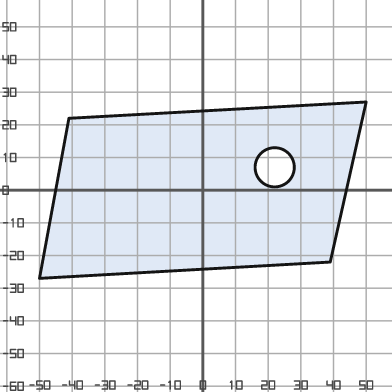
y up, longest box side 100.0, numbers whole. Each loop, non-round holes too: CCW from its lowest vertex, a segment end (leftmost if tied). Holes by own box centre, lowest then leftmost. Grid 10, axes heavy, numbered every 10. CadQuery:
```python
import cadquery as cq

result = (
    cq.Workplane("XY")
    .moveTo(-50.0, -27.0)
    .lineTo(39.0, -22.0)
    .lineTo(50.0, 27.0)
    .lineTo(-41.0, 22.0)
    .close()
    .moveTo(22.0, 7.0)
    .circle(6.0)
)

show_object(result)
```